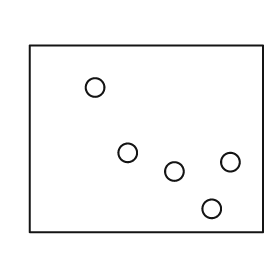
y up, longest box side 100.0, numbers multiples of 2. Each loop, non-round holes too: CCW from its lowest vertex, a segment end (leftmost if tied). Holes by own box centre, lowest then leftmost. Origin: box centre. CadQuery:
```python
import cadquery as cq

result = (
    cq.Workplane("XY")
    .moveTo(-50.0, -40.0)
    .lineTo(50.0, -40.0)
    .lineTo(50.0, 40.0)
    .lineTo(-50.0, 40.0)
    .close()
    .moveTo(28.0, -30.0)
    .circle(4.0)
    .moveTo(12.0, -14.0)
    .circle(4.0)
    .moveTo(36.0, -10.0)
    .circle(4.0)
    .moveTo(-8.0, -6.0)
    .circle(4.0)
    .moveTo(-22.0, 22.0)
    .circle(4.0)
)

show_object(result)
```